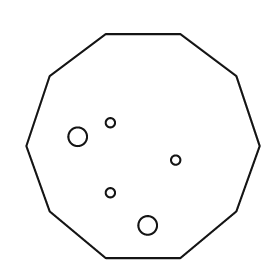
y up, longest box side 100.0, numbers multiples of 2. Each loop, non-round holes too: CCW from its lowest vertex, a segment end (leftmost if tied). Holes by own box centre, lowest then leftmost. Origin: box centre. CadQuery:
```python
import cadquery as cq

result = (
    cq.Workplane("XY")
    .moveTo(-16.0, -48.0)
    .lineTo(16.0, -48.0)
    .lineTo(40.0, -28.0)
    .lineTo(50.0, 0.0)
    .lineTo(40.0, 30.0)
    .lineTo(16.0, 48.0)
    .lineTo(-16.0, 48.0)
    .lineTo(-40.0, 30.0)
    .lineTo(-50.0, 0.0)
    .lineTo(-40.0, -28.0)
    .close()
    .moveTo(2.0, -34.0)
    .circle(4.0)
    .moveTo(-14.0, -20.0)
    .circle(2.0)
    .moveTo(14.0, -6.0)
    .circle(2.0)
    .moveTo(-28.0, 4.0)
    .circle(4.0)
    .moveTo(-14.0, 10.0)
    .circle(2.0)
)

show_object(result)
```